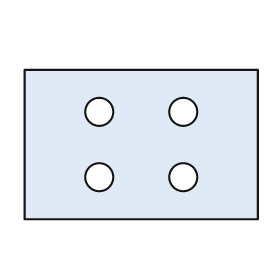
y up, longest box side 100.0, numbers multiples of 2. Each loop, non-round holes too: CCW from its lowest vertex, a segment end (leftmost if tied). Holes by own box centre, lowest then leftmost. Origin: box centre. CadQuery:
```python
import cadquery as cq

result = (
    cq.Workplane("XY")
    .moveTo(-50.0, -32.0)
    .lineTo(50.0, -32.0)
    .lineTo(50.0, 32.0)
    .lineTo(-50.0, 32.0)
    .close()
    .moveTo(-18.0, -14.0)
    .circle(6.0)
    .moveTo(18.0, -14.0)
    .circle(6.0)
    .moveTo(-18.0, 14.0)
    .circle(6.0)
    .moveTo(18.0, 14.0)
    .circle(6.0)
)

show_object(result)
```